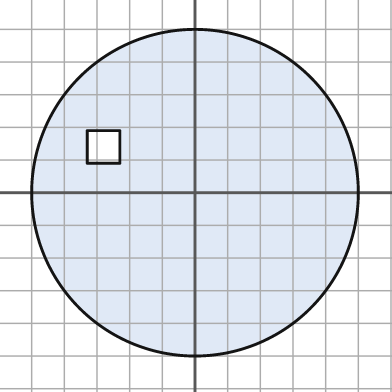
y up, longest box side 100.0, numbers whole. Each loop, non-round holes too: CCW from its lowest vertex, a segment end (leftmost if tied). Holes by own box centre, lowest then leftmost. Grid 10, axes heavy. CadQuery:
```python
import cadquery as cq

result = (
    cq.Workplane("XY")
    .moveTo(0.0, 0.0)
    .circle(50.0)
    .moveTo(-33.0, 9.0)
    .lineTo(-23.0, 9.0)
    .lineTo(-23.0, 19.0)
    .lineTo(-33.0, 19.0)
    .close()
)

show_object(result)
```